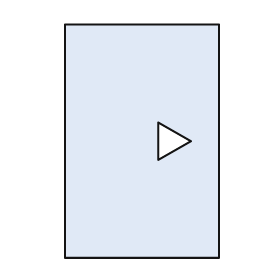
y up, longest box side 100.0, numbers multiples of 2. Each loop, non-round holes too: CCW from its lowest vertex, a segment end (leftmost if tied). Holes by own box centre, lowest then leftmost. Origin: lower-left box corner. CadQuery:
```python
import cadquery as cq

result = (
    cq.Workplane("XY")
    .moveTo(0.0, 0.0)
    .lineTo(66.0, 0.0)
    .lineTo(66.0, 100.0)
    .lineTo(0.0, 100.0)
    .close()
    .moveTo(40.0, 42.0)
    .lineTo(54.0, 50.0)
    .lineTo(40.0, 58.0)
    .close()
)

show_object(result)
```